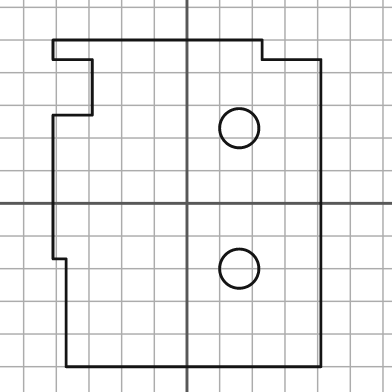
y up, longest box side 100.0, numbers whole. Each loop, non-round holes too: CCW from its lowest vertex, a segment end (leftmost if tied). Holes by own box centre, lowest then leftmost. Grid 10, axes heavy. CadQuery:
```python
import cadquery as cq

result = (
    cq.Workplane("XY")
    .moveTo(-37.0, -50.0)
    .lineTo(41.0, -50.0)
    .lineTo(41.0, 44.0)
    .lineTo(23.0, 44.0)
    .lineTo(23.0, 50.0)
    .lineTo(-41.0, 50.0)
    .lineTo(-41.0, 44.0)
    .lineTo(-29.0, 44.0)
    .lineTo(-29.0, 27.0)
    .lineTo(-41.0, 27.0)
    .lineTo(-41.0, -17.0)
    .lineTo(-37.0, -17.0)
    .close()
    .moveTo(16.0, -20.0)
    .circle(6.0)
    .moveTo(16.0, 23.0)
    .circle(6.0)
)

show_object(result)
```